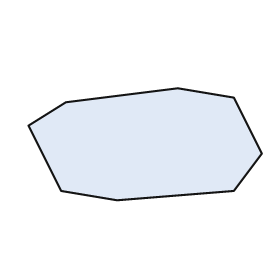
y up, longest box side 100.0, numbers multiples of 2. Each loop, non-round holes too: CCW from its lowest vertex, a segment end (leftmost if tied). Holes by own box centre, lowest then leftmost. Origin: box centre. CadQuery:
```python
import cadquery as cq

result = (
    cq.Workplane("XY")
    .moveTo(-12.0, -24.0)
    .lineTo(38.0, -20.0)
    .lineTo(50.0, -4.0)
    .lineTo(38.0, 20.0)
    .lineTo(14.0, 24.0)
    .lineTo(-34.0, 18.0)
    .lineTo(-50.0, 8.0)
    .lineTo(-36.0, -20.0)
    .close()
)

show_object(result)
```